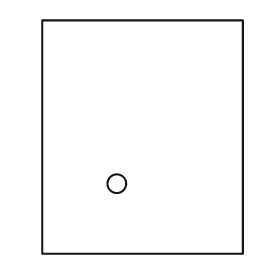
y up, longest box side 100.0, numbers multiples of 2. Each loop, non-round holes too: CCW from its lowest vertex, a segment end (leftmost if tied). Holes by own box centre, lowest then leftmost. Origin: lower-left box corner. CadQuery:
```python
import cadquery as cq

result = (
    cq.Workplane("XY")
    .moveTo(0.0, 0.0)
    .lineTo(86.0, 0.0)
    .lineTo(86.0, 100.0)
    .lineTo(0.0, 100.0)
    .close()
    .moveTo(32.0, 30.0)
    .circle(4.0)
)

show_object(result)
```